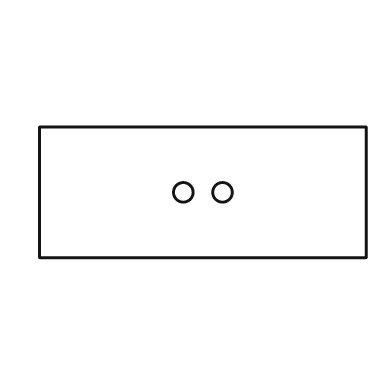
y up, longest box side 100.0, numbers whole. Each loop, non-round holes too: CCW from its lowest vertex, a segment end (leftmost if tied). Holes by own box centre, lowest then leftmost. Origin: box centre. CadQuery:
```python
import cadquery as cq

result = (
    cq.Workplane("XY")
    .moveTo(-50.0, -20.0)
    .lineTo(50.0, -20.0)
    .lineTo(50.0, 20.0)
    .lineTo(-50.0, 20.0)
    .close()
    .moveTo(-6.0, 0.0)
    .circle(3.0)
    .moveTo(6.0, 0.0)
    .circle(3.0)
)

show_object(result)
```